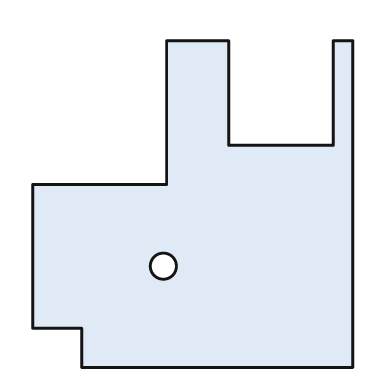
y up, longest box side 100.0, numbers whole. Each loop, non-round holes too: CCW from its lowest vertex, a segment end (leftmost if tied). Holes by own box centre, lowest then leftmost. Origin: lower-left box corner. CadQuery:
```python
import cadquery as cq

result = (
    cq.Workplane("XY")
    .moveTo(15.0, 0.0)
    .lineTo(98.0, 0.0)
    .lineTo(98.0, 100.0)
    .lineTo(92.0, 100.0)
    .lineTo(92.0, 68.0)
    .lineTo(60.0, 68.0)
    .lineTo(60.0, 100.0)
    .lineTo(41.0, 100.0)
    .lineTo(41.0, 56.0)
    .lineTo(0.0, 56.0)
    .lineTo(0.0, 12.0)
    .lineTo(15.0, 12.0)
    .close()
    .moveTo(40.0, 31.0)
    .circle(4.0)
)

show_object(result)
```